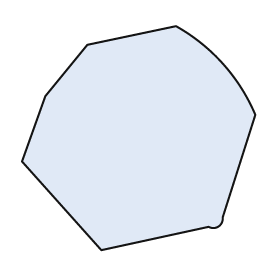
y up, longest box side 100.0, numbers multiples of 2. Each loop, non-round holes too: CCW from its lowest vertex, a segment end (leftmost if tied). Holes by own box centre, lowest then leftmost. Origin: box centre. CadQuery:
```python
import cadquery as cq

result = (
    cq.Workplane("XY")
    .moveTo(-16.0, -48.0)
    .lineTo(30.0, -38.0)
    .threePointArc((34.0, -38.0), (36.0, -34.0))
    .lineTo(50.0, 10.0)
    .threePointArc((36.0, 32.0), (16.0, 48.0))
    .lineTo(-22.0, 40.0)
    .lineTo(-40.0, 18.0)
    .lineTo(-50.0, -10.0)
    .close()
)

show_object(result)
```